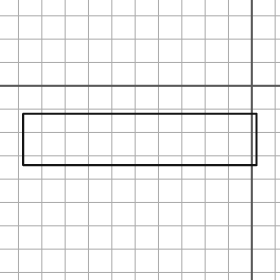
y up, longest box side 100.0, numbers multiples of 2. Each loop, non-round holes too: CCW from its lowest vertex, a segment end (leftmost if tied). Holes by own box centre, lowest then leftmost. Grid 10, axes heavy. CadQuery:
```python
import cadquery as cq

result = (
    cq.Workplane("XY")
    .moveTo(-98.0, -34.0)
    .lineTo(2.0, -34.0)
    .lineTo(2.0, -12.0)
    .lineTo(-98.0, -12.0)
    .close()
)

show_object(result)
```